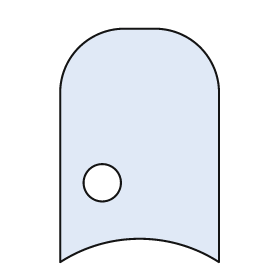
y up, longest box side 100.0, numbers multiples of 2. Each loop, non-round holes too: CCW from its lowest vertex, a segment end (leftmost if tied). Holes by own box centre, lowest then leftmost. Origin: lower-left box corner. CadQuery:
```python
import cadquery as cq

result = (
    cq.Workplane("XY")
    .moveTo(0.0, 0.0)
    .threePointArc((34.0, 10.0), (68.0, 0.0))
    .lineTo(68.0, 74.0)
    .threePointArc((60.0, 92.0), (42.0, 100.0))
    .lineTo(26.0, 100.0)
    .threePointArc((8.0, 92.0), (0.0, 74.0))
    .close()
    .moveTo(18.0, 34.0)
    .circle(8.0)
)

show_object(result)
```